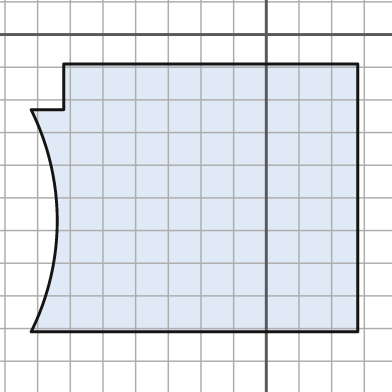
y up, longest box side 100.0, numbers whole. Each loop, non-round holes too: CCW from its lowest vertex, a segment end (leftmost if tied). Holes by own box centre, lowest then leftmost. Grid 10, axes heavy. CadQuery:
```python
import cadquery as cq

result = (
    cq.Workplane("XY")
    .moveTo(-72.0, -91.0)
    .lineTo(28.0, -91.0)
    .lineTo(28.0, -9.0)
    .lineTo(-62.0, -9.0)
    .lineTo(-62.0, -23.0)
    .lineTo(-72.0, -23.0)
    .threePointArc((-64.0, -57.0), (-72.0, -91.0))
    .close()
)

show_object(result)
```